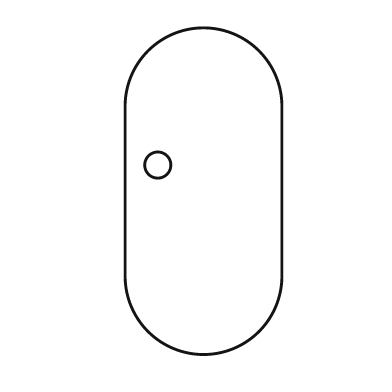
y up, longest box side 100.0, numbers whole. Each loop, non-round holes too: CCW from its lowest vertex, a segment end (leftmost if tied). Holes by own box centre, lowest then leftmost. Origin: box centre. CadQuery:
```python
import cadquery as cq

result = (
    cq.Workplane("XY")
    .moveTo(-24.0, -26.0)
    .threePointArc((0.0, -50.0), (24.0, -26.0))
    .lineTo(24.0, 26.0)
    .threePointArc((0.0, 50.0), (-24.0, 26.0))
    .close()
    .moveTo(-14.0, 8.0)
    .circle(4.0)
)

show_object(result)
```